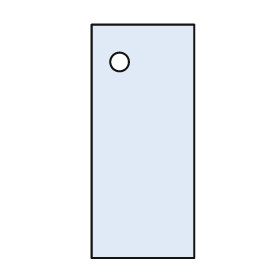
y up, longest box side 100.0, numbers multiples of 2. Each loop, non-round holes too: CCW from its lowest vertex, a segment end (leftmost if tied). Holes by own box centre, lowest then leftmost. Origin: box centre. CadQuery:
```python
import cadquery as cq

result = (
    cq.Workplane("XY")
    .moveTo(-22.0, -50.0)
    .lineTo(22.0, -50.0)
    .lineTo(22.0, 50.0)
    .lineTo(-22.0, 50.0)
    .close()
    .moveTo(-10.0, 34.0)
    .circle(4.0)
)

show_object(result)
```